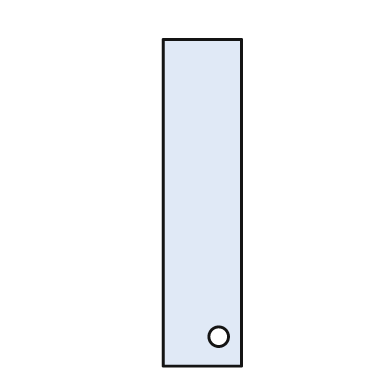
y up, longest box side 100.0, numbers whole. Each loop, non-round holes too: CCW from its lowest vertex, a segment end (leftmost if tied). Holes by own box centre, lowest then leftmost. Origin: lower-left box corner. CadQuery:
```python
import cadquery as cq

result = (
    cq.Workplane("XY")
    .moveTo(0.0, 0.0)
    .lineTo(24.0, 0.0)
    .lineTo(24.0, 100.0)
    .lineTo(0.0, 100.0)
    .close()
    .moveTo(17.0, 9.0)
    .circle(3.0)
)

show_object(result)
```